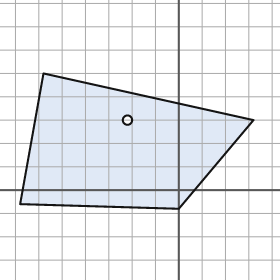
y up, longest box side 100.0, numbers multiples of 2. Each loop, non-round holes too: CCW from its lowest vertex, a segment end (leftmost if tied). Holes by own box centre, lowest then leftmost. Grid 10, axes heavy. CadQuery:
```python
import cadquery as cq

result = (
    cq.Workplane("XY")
    .moveTo(0.0, -8.0)
    .lineTo(32.0, 30.0)
    .lineTo(-58.0, 50.0)
    .lineTo(-68.0, -6.0)
    .close()
    .moveTo(-22.0, 30.0)
    .circle(2.0)
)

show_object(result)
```